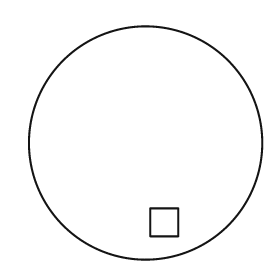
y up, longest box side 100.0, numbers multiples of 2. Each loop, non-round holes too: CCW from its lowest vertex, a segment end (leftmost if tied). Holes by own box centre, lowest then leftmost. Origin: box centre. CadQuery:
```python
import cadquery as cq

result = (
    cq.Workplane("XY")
    .moveTo(0.0, 0.0)
    .circle(50.0)
    .moveTo(2.0, -40.0)
    .lineTo(14.0, -40.0)
    .lineTo(14.0, -28.0)
    .lineTo(2.0, -28.0)
    .close()
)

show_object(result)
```